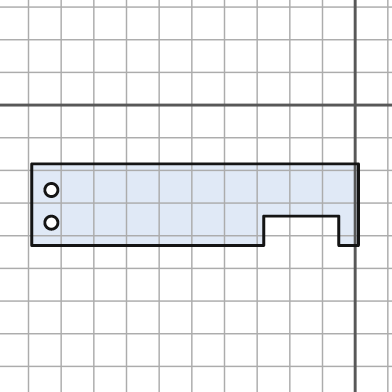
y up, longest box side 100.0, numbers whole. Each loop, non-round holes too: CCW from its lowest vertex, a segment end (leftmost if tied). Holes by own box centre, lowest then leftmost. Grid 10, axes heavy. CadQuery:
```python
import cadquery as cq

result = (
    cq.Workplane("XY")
    .moveTo(-99.0, -43.0)
    .lineTo(-28.0, -43.0)
    .lineTo(-28.0, -34.0)
    .lineTo(-5.0, -34.0)
    .lineTo(-5.0, -43.0)
    .lineTo(1.0, -43.0)
    .lineTo(1.0, -18.0)
    .lineTo(-99.0, -18.0)
    .close()
    .moveTo(-93.0, -36.0)
    .circle(2.0)
    .moveTo(-93.0, -26.0)
    .circle(2.0)
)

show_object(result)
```